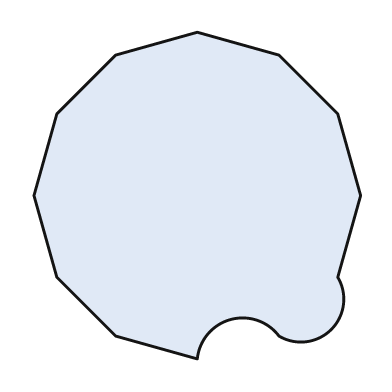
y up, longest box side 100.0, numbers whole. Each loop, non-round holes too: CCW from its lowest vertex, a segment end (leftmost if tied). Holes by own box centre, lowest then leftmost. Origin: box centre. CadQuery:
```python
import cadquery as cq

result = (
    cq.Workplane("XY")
    .moveTo(0.0, -50.0)
    .threePointArc((10.0, -38.0), (25.0, -43.0))
    .threePointArc((41.0, -41.0), (43.0, -25.0))
    .lineTo(50.0, 0.0)
    .lineTo(43.0, 25.0)
    .lineTo(25.0, 43.0)
    .lineTo(0.0, 50.0)
    .lineTo(-25.0, 43.0)
    .lineTo(-43.0, 25.0)
    .lineTo(-50.0, 0.0)
    .lineTo(-43.0, -25.0)
    .lineTo(-25.0, -43.0)
    .close()
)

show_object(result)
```